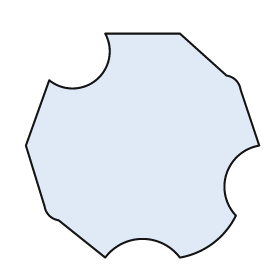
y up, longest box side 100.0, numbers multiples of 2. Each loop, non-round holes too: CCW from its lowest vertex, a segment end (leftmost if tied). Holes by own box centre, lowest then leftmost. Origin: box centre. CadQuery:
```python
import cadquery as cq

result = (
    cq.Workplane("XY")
    .moveTo(-16.0, -48.0)
    .threePointArc((0.0, -40.0), (16.0, -48.0))
    .threePointArc((30.0, -42.0), (40.0, -30.0))
    .threePointArc((36.0, -12.0), (50.0, 0.0))
    .lineTo(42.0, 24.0)
    .threePointArc((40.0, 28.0), (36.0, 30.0))
    .lineTo(16.0, 48.0)
    .lineTo(-16.0, 48.0)
    .threePointArc((-20.0, 28.0), (-40.0, 28.0))
    .lineTo(-50.0, 0.0)
    .lineTo(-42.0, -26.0)
    .threePointArc((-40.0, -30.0), (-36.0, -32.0))
    .close()
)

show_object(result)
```